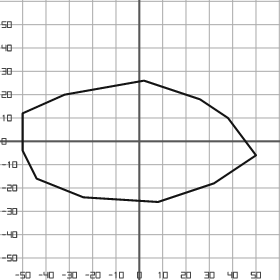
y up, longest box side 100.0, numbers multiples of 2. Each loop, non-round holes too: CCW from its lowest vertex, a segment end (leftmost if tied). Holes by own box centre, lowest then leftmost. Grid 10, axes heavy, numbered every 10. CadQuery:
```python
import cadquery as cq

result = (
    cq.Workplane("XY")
    .moveTo(8.0, -26.0)
    .lineTo(32.0, -18.0)
    .lineTo(50.0, -6.0)
    .lineTo(38.0, 10.0)
    .lineTo(26.0, 18.0)
    .lineTo(2.0, 26.0)
    .lineTo(-32.0, 20.0)
    .lineTo(-50.0, 12.0)
    .lineTo(-50.0, -4.0)
    .lineTo(-44.0, -16.0)
    .lineTo(-24.0, -24.0)
    .close()
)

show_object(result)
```